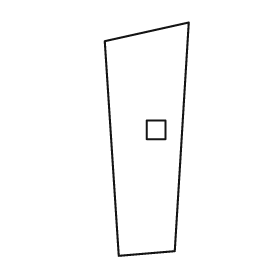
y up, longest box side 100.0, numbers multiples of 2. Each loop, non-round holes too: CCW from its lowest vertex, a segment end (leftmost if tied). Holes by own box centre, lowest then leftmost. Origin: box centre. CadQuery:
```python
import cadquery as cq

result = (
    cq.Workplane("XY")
    .moveTo(-12.0, -50.0)
    .lineTo(12.0, -48.0)
    .lineTo(18.0, 50.0)
    .lineTo(-18.0, 42.0)
    .close()
    .moveTo(0.0, 0.0)
    .lineTo(8.0, 0.0)
    .lineTo(8.0, 8.0)
    .lineTo(0.0, 8.0)
    .close()
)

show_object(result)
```